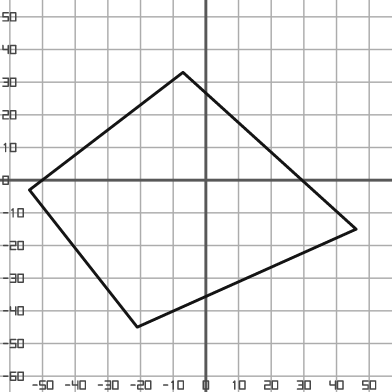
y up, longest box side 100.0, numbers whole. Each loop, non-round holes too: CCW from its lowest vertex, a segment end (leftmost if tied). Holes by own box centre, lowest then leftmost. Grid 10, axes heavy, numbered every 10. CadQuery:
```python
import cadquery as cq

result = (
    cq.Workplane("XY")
    .moveTo(-21.0, -45.0)
    .lineTo(46.0, -15.0)
    .lineTo(-7.0, 33.0)
    .lineTo(-54.0, -3.0)
    .close()
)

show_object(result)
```